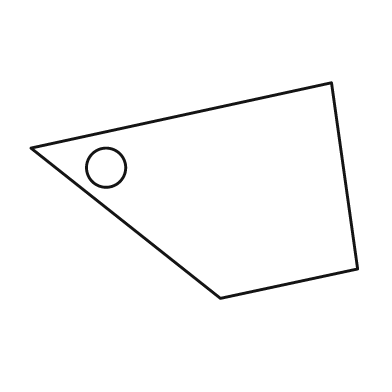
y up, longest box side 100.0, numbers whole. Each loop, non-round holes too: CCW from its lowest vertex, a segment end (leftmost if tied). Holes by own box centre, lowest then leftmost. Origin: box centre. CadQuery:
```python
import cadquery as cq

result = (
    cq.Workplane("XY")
    .moveTo(8.0, -33.0)
    .lineTo(50.0, -24.0)
    .lineTo(42.0, 33.0)
    .lineTo(-50.0, 13.0)
    .close()
    .moveTo(-27.0, 7.0)
    .circle(6.0)
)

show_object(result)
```